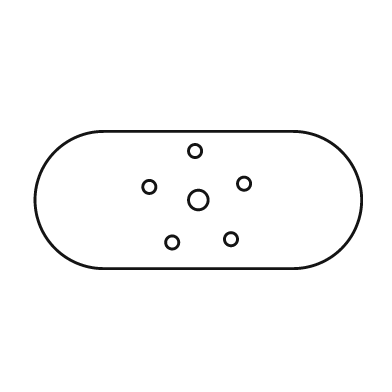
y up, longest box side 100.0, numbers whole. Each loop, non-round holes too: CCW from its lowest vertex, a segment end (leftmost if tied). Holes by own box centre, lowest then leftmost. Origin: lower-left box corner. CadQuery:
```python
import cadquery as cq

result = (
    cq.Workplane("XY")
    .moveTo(21.0, 0.0)
    .lineTo(79.0, 0.0)
    .threePointArc((100.0, 21.0), (79.0, 42.0))
    .lineTo(21.0, 42.0)
    .threePointArc((0.0, 21.0), (21.0, 0.0))
    .close()
    .moveTo(42.0, 8.0)
    .circle(2.0)
    .moveTo(60.0, 9.0)
    .circle(2.0)
    .moveTo(50.0, 21.0)
    .circle(3.0)
    .moveTo(35.0, 25.0)
    .circle(2.0)
    .moveTo(64.0, 26.0)
    .circle(2.0)
    .moveTo(49.0, 36.0)
    .circle(2.0)
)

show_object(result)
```